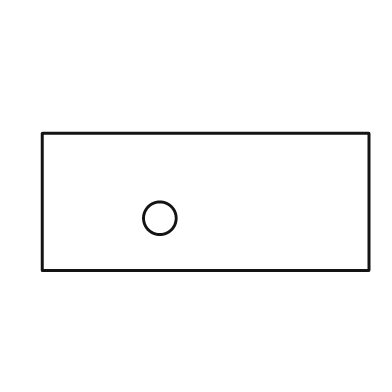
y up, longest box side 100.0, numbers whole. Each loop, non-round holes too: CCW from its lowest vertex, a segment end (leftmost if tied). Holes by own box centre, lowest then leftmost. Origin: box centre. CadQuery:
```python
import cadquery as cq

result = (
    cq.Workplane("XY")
    .moveTo(-50.0, -21.0)
    .lineTo(50.0, -21.0)
    .lineTo(50.0, 21.0)
    .lineTo(-50.0, 21.0)
    .close()
    .moveTo(-14.0, -5.0)
    .circle(5.0)
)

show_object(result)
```